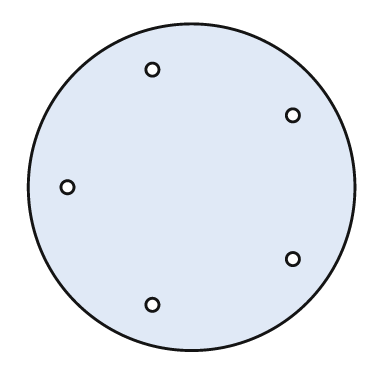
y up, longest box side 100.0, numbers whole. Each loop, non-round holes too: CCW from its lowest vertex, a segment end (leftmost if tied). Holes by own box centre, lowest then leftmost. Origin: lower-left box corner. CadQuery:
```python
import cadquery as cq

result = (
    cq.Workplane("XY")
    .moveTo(50.0, 50.0)
    .circle(50.0)
    .moveTo(38.0, 14.0)
    .circle(2.0)
    .moveTo(81.0, 28.0)
    .circle(2.0)
    .moveTo(12.0, 50.0)
    .circle(2.0)
    .moveTo(81.0, 72.0)
    .circle(2.0)
    .moveTo(38.0, 86.0)
    .circle(2.0)
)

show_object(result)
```